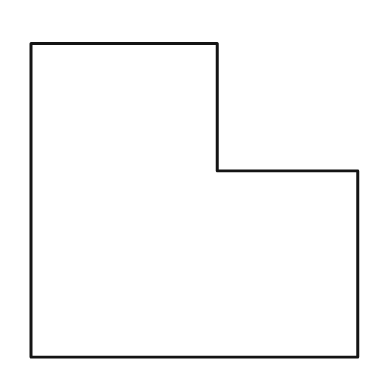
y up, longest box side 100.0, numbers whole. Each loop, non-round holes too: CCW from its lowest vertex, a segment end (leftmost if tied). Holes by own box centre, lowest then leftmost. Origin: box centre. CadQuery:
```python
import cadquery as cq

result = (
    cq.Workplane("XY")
    .moveTo(-50.0, -48.0)
    .lineTo(50.0, -48.0)
    .lineTo(50.0, 9.0)
    .lineTo(7.0, 9.0)
    .lineTo(7.0, 48.0)
    .lineTo(-50.0, 48.0)
    .close()
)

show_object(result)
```